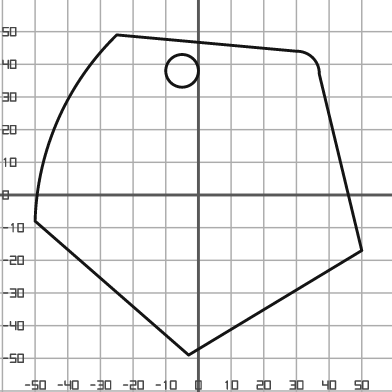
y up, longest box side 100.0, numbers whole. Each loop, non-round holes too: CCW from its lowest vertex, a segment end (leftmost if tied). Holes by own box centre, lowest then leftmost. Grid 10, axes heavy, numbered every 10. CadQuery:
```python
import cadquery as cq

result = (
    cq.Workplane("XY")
    .moveTo(-3.0, -49.0)
    .lineTo(50.0, -17.0)
    .lineTo(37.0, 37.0)
    .threePointArc((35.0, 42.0), (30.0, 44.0))
    .lineTo(-25.0, 49.0)
    .threePointArc((-43.0, 23.0), (-50.0, -8.0))
    .close()
    .moveTo(-5.0, 38.0)
    .circle(5.0)
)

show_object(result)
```